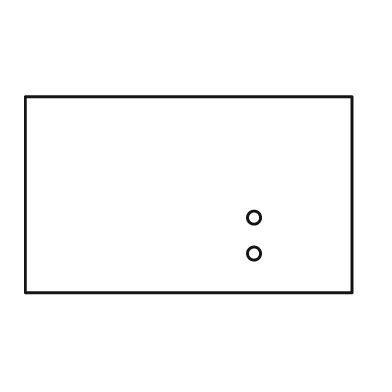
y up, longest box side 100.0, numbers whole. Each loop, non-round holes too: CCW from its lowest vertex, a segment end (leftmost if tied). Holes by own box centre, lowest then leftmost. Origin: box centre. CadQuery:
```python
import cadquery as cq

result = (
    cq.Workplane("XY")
    .moveTo(-50.0, -30.0)
    .lineTo(50.0, -30.0)
    .lineTo(50.0, 30.0)
    .lineTo(-50.0, 30.0)
    .close()
    .moveTo(20.0, -18.0)
    .circle(2.0)
    .moveTo(20.0, -7.0)
    .circle(2.0)
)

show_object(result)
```